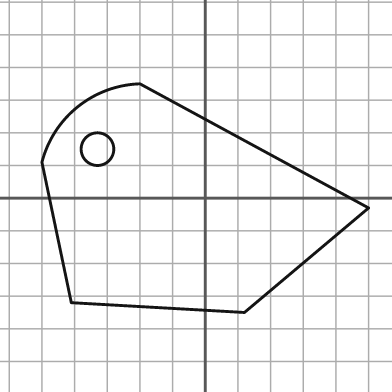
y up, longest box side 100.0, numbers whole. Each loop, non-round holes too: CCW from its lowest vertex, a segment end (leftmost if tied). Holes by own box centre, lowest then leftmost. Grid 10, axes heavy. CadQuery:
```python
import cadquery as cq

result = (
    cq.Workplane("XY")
    .moveTo(12.0, -35.0)
    .lineTo(50.0, -3.0)
    .lineTo(-20.0, 35.0)
    .threePointArc((-39.0, 28.0), (-50.0, 11.0))
    .lineTo(-41.0, -32.0)
    .close()
    .moveTo(-33.0, 15.0)
    .circle(5.0)
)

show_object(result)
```